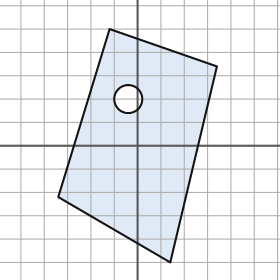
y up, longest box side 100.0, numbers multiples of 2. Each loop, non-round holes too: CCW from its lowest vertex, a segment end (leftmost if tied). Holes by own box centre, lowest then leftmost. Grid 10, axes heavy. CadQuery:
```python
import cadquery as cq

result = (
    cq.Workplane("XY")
    .moveTo(14.0, -50.0)
    .lineTo(34.0, 34.0)
    .lineTo(-12.0, 50.0)
    .lineTo(-34.0, -22.0)
    .close()
    .moveTo(-4.0, 20.0)
    .circle(6.0)
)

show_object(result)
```